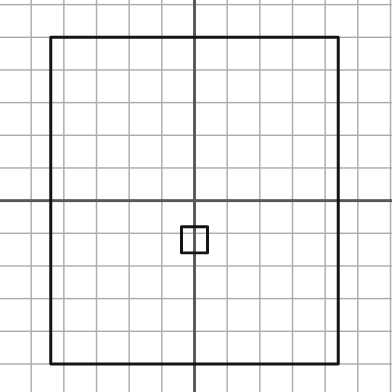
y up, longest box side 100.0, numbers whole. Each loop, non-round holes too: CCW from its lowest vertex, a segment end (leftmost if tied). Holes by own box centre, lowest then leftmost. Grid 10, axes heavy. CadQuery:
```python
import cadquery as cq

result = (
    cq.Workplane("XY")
    .moveTo(-44.0, -50.0)
    .lineTo(44.0, -50.0)
    .lineTo(44.0, 50.0)
    .lineTo(-44.0, 50.0)
    .close()
    .moveTo(-4.0, -16.0)
    .lineTo(4.0, -16.0)
    .lineTo(4.0, -8.0)
    .lineTo(-4.0, -8.0)
    .close()
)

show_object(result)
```